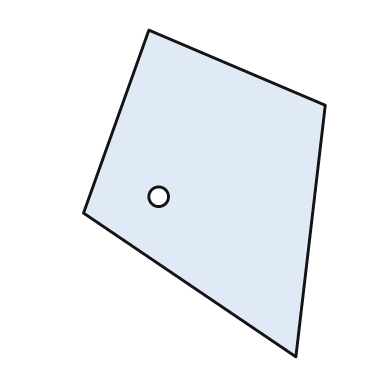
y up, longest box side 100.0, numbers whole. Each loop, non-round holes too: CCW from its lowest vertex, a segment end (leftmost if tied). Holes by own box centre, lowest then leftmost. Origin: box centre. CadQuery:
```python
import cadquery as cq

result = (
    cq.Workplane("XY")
    .moveTo(28.0, -50.0)
    .lineTo(37.0, 27.0)
    .lineTo(-17.0, 50.0)
    .lineTo(-37.0, -6.0)
    .close()
    .moveTo(-14.0, -1.0)
    .circle(3.0)
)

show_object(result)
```